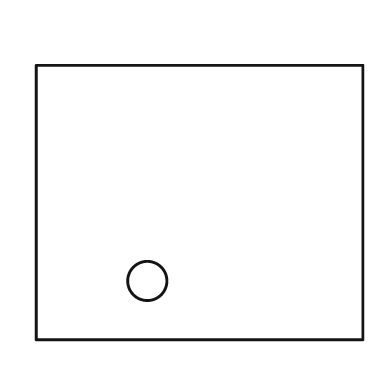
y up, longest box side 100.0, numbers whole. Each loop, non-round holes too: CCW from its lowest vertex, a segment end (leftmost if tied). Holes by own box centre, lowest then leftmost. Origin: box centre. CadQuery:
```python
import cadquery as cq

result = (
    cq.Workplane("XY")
    .moveTo(-50.0, -42.0)
    .lineTo(50.0, -42.0)
    .lineTo(50.0, 42.0)
    .lineTo(-50.0, 42.0)
    .close()
    .moveTo(-16.0, -24.0)
    .circle(6.0)
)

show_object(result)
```